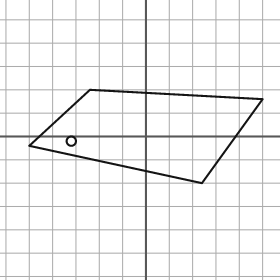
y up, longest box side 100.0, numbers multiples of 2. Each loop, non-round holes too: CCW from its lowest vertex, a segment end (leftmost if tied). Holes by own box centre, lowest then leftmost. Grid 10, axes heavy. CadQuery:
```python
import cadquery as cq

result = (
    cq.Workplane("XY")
    .moveTo(24.0, -20.0)
    .lineTo(50.0, 16.0)
    .lineTo(-24.0, 20.0)
    .lineTo(-50.0, -4.0)
    .close()
    .moveTo(-32.0, -2.0)
    .circle(2.0)
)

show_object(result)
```